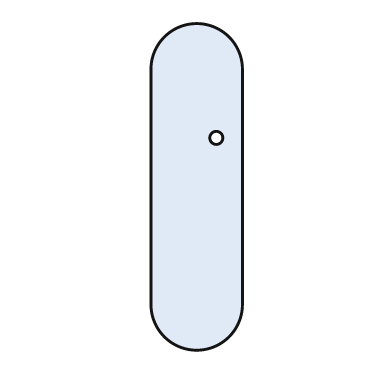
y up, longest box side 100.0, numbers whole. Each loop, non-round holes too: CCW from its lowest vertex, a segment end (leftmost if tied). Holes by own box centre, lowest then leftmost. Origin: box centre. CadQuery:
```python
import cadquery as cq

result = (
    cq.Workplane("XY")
    .moveTo(-14.0, -36.0)
    .threePointArc((0.0, -50.0), (14.0, -36.0))
    .lineTo(14.0, 36.0)
    .threePointArc((0.0, 50.0), (-14.0, 36.0))
    .close()
    .moveTo(6.0, 15.0)
    .circle(2.0)
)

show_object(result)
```